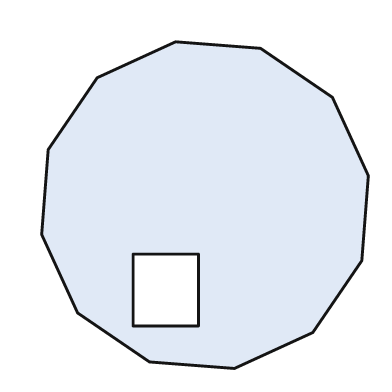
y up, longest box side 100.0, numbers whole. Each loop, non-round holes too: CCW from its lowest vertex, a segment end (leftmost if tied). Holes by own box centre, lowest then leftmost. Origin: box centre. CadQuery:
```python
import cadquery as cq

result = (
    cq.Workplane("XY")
    .moveTo(9.0, -50.0)
    .lineTo(33.0, -39.0)
    .lineTo(48.0, -17.0)
    .lineTo(50.0, 9.0)
    .lineTo(39.0, 33.0)
    .lineTo(17.0, 48.0)
    .lineTo(-9.0, 50.0)
    .lineTo(-33.0, 39.0)
    .lineTo(-48.0, 17.0)
    .lineTo(-50.0, -9.0)
    .lineTo(-39.0, -33.0)
    .lineTo(-17.0, -48.0)
    .close()
    .moveTo(-22.0, -37.0)
    .lineTo(-2.0, -37.0)
    .lineTo(-2.0, -15.0)
    .lineTo(-22.0, -15.0)
    .close()
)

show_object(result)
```